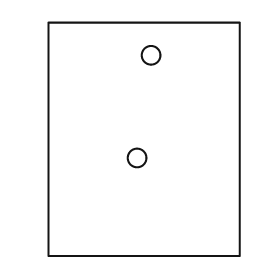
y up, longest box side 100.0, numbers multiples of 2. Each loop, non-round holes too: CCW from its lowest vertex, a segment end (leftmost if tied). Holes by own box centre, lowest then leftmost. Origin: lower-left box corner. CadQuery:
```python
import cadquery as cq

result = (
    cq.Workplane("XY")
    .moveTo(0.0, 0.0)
    .lineTo(82.0, 0.0)
    .lineTo(82.0, 100.0)
    .lineTo(0.0, 100.0)
    .close()
    .moveTo(38.0, 42.0)
    .circle(4.0)
    .moveTo(44.0, 86.0)
    .circle(4.0)
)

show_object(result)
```